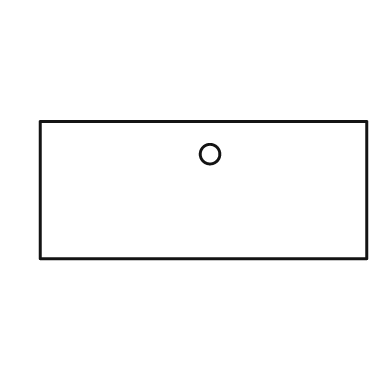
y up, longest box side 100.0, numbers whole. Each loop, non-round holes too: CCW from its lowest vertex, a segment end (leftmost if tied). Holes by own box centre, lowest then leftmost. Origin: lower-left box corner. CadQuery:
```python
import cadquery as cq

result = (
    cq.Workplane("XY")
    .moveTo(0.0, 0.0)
    .lineTo(100.0, 0.0)
    .lineTo(100.0, 42.0)
    .lineTo(0.0, 42.0)
    .close()
    .moveTo(52.0, 32.0)
    .circle(3.0)
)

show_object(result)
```